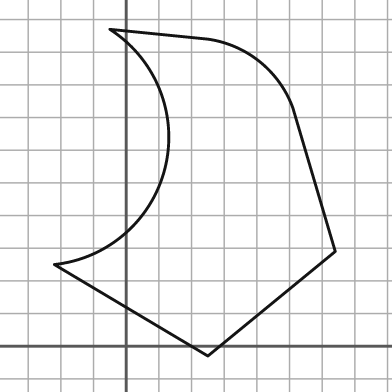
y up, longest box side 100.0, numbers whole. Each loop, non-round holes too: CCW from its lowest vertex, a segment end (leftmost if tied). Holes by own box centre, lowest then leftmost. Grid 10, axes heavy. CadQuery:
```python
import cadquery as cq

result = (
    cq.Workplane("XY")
    .moveTo(25.0, -3.0)
    .lineTo(64.0, 29.0)
    .lineTo(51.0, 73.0)
    .threePointArc((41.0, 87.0), (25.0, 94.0))
    .lineTo(-5.0, 97.0)
    .threePointArc((12.0, 55.0), (-22.0, 25.0))
    .close()
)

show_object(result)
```